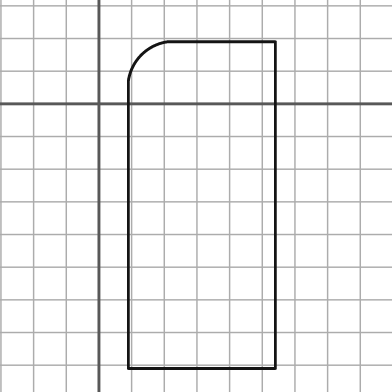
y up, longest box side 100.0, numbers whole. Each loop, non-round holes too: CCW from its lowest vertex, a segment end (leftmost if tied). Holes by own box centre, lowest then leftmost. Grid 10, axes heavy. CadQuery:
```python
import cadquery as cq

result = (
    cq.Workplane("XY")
    .moveTo(9.0, -81.0)
    .lineTo(54.0, -81.0)
    .lineTo(54.0, 19.0)
    .lineTo(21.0, 19.0)
    .threePointArc((13.0, 15.0), (9.0, 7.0))
    .close()
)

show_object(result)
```